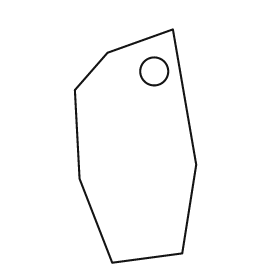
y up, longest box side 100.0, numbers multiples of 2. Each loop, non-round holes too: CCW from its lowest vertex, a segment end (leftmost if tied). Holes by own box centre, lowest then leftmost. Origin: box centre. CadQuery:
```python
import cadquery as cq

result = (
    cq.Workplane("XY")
    .moveTo(-10.0, -50.0)
    .lineTo(20.0, -46.0)
    .lineTo(26.0, -8.0)
    .lineTo(16.0, 50.0)
    .lineTo(-12.0, 40.0)
    .lineTo(-26.0, 24.0)
    .lineTo(-24.0, -14.0)
    .close()
    .moveTo(8.0, 32.0)
    .circle(6.0)
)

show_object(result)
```